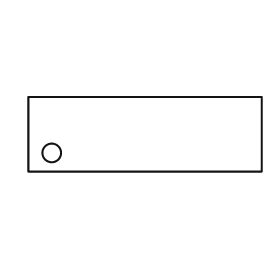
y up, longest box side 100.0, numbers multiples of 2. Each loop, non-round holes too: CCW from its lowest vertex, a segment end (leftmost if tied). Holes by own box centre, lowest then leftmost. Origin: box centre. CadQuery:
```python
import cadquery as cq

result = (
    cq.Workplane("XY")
    .moveTo(-50.0, -16.0)
    .lineTo(50.0, -16.0)
    .lineTo(50.0, 16.0)
    .lineTo(-50.0, 16.0)
    .close()
    .moveTo(-40.0, -8.0)
    .circle(4.0)
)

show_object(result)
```